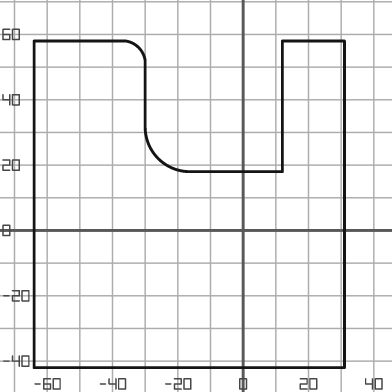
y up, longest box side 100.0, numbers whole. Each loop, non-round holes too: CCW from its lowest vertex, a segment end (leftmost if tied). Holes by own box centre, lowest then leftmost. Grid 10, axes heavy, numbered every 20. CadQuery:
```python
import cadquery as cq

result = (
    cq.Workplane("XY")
    .moveTo(-64.0, -42.0)
    .lineTo(31.0, -42.0)
    .lineTo(31.0, 58.0)
    .lineTo(12.0, 58.0)
    .lineTo(12.0, 18.0)
    .lineTo(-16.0, 18.0)
    .threePointArc((-26.0, 22.0), (-30.0, 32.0))
    .lineTo(-30.0, 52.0)
    .threePointArc((-32.0, 56.0), (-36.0, 58.0))
    .lineTo(-64.0, 58.0)
    .close()
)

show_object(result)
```